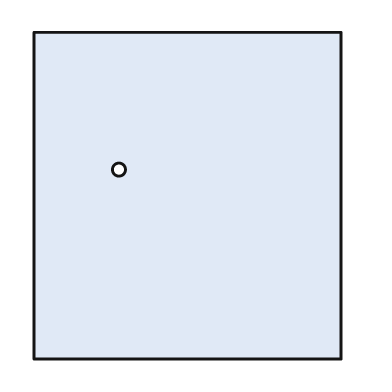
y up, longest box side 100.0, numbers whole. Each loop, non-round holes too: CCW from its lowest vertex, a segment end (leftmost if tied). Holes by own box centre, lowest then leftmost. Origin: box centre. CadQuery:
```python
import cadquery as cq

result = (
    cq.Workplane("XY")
    .moveTo(-47.0, -50.0)
    .lineTo(47.0, -50.0)
    .lineTo(47.0, 50.0)
    .lineTo(-47.0, 50.0)
    .close()
    .moveTo(-21.0, 8.0)
    .circle(2.0)
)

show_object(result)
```